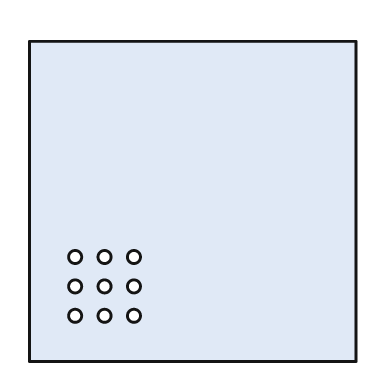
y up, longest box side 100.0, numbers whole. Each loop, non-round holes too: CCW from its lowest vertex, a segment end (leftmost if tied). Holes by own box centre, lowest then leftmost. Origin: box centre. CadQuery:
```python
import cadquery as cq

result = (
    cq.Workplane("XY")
    .moveTo(-50.0, -49.0)
    .lineTo(50.0, -49.0)
    .lineTo(50.0, 49.0)
    .lineTo(-50.0, 49.0)
    .close()
    .moveTo(-36.0, -35.0)
    .circle(2.0)
    .moveTo(-27.0, -35.0)
    .circle(2.0)
    .moveTo(-18.0, -35.0)
    .circle(2.0)
    .moveTo(-36.0, -26.0)
    .circle(2.0)
    .moveTo(-27.0, -26.0)
    .circle(2.0)
    .moveTo(-18.0, -26.0)
    .circle(2.0)
    .moveTo(-36.0, -17.0)
    .circle(2.0)
    .moveTo(-27.0, -17.0)
    .circle(2.0)
    .moveTo(-18.0, -17.0)
    .circle(2.0)
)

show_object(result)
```